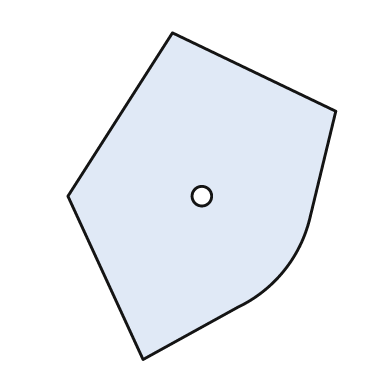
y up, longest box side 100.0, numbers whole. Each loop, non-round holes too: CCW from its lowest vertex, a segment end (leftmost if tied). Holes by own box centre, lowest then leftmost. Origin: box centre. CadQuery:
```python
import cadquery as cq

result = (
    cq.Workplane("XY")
    .moveTo(-18.0, -50.0)
    .lineTo(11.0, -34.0)
    .threePointArc((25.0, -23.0), (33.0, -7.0))
    .lineTo(41.0, 26.0)
    .lineTo(-9.0, 50.0)
    .lineTo(-41.0, 0.0)
    .close()
    .moveTo(0.0, 0.0)
    .circle(3.0)
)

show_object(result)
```